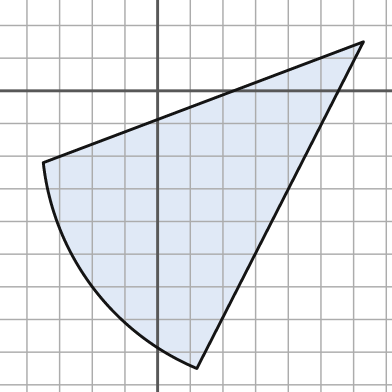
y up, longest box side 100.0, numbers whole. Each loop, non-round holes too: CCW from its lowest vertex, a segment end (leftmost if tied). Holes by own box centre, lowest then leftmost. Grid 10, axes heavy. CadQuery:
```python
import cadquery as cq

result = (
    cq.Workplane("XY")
    .moveTo(12.0, -85.0)
    .lineTo(63.0, 15.0)
    .lineTo(-35.0, -22.0)
    .threePointArc((-20.0, -60.0), (12.0, -85.0))
    .close()
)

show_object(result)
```